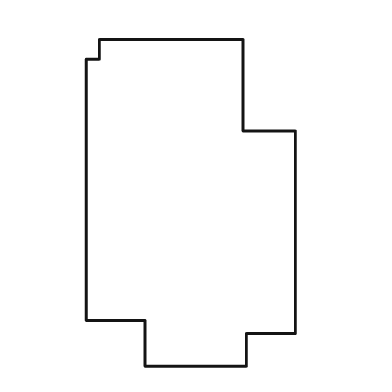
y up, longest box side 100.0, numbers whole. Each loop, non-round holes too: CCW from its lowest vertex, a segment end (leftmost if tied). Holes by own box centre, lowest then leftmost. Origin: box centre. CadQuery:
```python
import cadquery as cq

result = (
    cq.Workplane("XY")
    .moveTo(-14.0, -50.0)
    .lineTo(17.0, -50.0)
    .lineTo(17.0, -40.0)
    .lineTo(32.0, -40.0)
    .lineTo(32.0, 22.0)
    .lineTo(16.0, 22.0)
    .lineTo(16.0, 50.0)
    .lineTo(-28.0, 50.0)
    .lineTo(-28.0, 44.0)
    .lineTo(-32.0, 44.0)
    .lineTo(-32.0, -36.0)
    .lineTo(-14.0, -36.0)
    .close()
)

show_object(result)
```